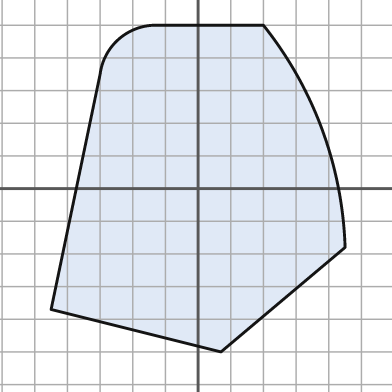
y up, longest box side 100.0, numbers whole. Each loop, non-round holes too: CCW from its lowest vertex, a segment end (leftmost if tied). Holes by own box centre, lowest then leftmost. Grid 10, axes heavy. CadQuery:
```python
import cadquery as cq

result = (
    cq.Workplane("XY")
    .moveTo(7.0, -50.0)
    .lineTo(45.0, -18.0)
    .threePointArc((38.0, 18.0), (20.0, 50.0))
    .lineTo(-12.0, 50.0)
    .threePointArc((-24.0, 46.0), (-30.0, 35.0))
    .lineTo(-45.0, -37.0)
    .close()
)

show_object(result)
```